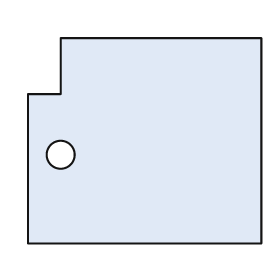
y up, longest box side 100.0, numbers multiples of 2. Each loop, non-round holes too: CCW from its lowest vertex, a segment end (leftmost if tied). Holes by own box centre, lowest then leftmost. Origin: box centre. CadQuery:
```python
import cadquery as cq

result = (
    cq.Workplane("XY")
    .moveTo(-50.0, -44.0)
    .lineTo(50.0, -44.0)
    .lineTo(50.0, 44.0)
    .lineTo(-36.0, 44.0)
    .lineTo(-36.0, 20.0)
    .lineTo(-50.0, 20.0)
    .close()
    .moveTo(-36.0, -6.0)
    .circle(6.0)
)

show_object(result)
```